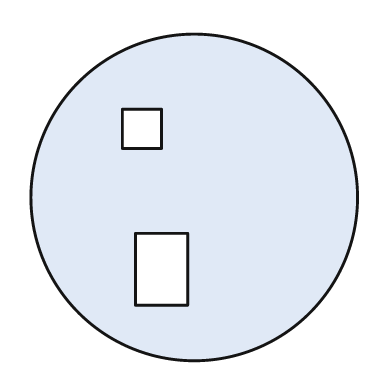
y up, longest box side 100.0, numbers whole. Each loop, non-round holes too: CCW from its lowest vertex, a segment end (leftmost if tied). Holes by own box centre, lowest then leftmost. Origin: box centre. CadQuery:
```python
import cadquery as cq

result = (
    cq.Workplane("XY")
    .moveTo(0.0, 0.0)
    .circle(50.0)
    .moveTo(-18.0, -33.0)
    .lineTo(-2.0, -33.0)
    .lineTo(-2.0, -11.0)
    .lineTo(-18.0, -11.0)
    .close()
    .moveTo(-22.0, 15.0)
    .lineTo(-10.0, 15.0)
    .lineTo(-10.0, 27.0)
    .lineTo(-22.0, 27.0)
    .close()
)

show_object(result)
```